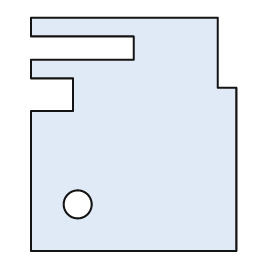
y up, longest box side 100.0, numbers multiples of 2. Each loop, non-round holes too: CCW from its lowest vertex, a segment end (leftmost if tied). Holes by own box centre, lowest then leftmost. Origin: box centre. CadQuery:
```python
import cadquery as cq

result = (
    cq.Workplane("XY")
    .moveTo(-44.0, -50.0)
    .lineTo(44.0, -50.0)
    .lineTo(44.0, 20.0)
    .lineTo(36.0, 20.0)
    .lineTo(36.0, 50.0)
    .lineTo(-44.0, 50.0)
    .lineTo(-44.0, 42.0)
    .lineTo(0.0, 42.0)
    .lineTo(0.0, 32.0)
    .lineTo(-44.0, 32.0)
    .lineTo(-44.0, 24.0)
    .lineTo(-26.0, 24.0)
    .lineTo(-26.0, 10.0)
    .lineTo(-44.0, 10.0)
    .close()
    .moveTo(-24.0, -30.0)
    .circle(6.0)
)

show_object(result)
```